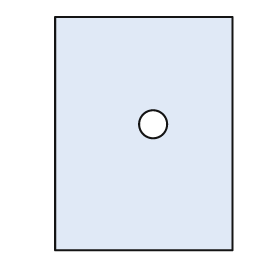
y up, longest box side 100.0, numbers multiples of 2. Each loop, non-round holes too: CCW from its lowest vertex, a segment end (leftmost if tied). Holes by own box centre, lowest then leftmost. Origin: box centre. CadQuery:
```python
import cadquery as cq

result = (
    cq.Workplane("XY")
    .moveTo(-38.0, -50.0)
    .lineTo(38.0, -50.0)
    .lineTo(38.0, 50.0)
    .lineTo(-38.0, 50.0)
    .close()
    .moveTo(4.0, 4.0)
    .circle(6.0)
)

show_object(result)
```